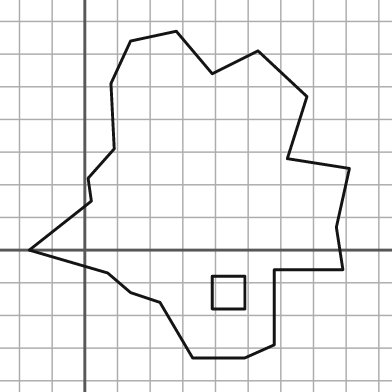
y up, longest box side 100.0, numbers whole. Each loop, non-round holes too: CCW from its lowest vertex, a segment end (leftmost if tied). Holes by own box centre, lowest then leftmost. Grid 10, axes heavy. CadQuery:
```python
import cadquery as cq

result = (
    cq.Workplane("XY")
    .moveTo(33.0, -33.0)
    .lineTo(49.0, -33.0)
    .lineTo(58.0, -29.0)
    .lineTo(58.0, -6.0)
    .lineTo(79.0, -6.0)
    .lineTo(77.0, 7.0)
    .lineTo(81.0, 25.0)
    .lineTo(62.0, 28.0)
    .lineTo(68.0, 47.0)
    .lineTo(53.0, 61.0)
    .lineTo(39.0, 54.0)
    .lineTo(28.0, 67.0)
    .lineTo(14.0, 64.0)
    .lineTo(8.0, 51.0)
    .lineTo(9.0, 31.0)
    .lineTo(1.0, 22.0)
    .lineTo(2.0, 15.0)
    .lineTo(-17.0, 0.0)
    .lineTo(7.0, -7.0)
    .lineTo(14.0, -13.0)
    .lineTo(23.0, -16.0)
    .close()
    .moveTo(39.0, -18.0)
    .lineTo(49.0, -18.0)
    .lineTo(49.0, -8.0)
    .lineTo(39.0, -8.0)
    .close()
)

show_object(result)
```